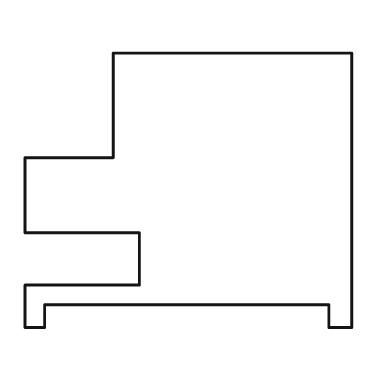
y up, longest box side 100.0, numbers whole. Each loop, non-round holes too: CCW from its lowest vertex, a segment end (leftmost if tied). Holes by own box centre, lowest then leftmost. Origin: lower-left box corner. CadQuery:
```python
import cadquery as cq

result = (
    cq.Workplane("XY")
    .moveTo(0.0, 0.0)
    .lineTo(6.0, 0.0)
    .lineTo(6.0, 7.0)
    .lineTo(93.0, 7.0)
    .lineTo(93.0, 0.0)
    .lineTo(100.0, 0.0)
    .lineTo(100.0, 84.0)
    .lineTo(27.0, 84.0)
    .lineTo(27.0, 52.0)
    .lineTo(0.0, 52.0)
    .lineTo(0.0, 29.0)
    .lineTo(35.0, 29.0)
    .lineTo(35.0, 13.0)
    .lineTo(0.0, 13.0)
    .close()
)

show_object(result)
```